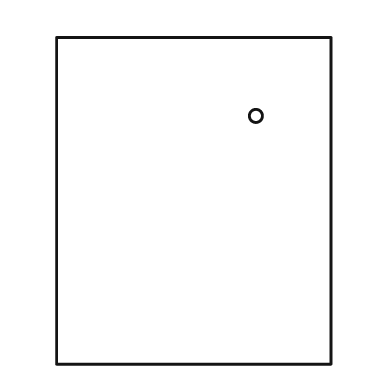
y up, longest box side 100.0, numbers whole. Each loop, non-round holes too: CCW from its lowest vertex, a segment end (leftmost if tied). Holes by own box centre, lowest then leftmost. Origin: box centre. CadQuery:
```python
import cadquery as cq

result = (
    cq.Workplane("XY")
    .moveTo(-42.0, -50.0)
    .lineTo(42.0, -50.0)
    .lineTo(42.0, 50.0)
    .lineTo(-42.0, 50.0)
    .close()
    .moveTo(19.0, 26.0)
    .circle(2.0)
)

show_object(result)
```